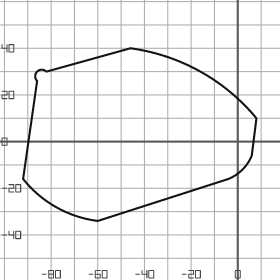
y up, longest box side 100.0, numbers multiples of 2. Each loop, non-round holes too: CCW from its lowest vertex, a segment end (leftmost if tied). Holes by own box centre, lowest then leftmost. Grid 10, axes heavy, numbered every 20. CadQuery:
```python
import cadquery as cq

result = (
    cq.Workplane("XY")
    .moveTo(-60.0, -34.0)
    .lineTo(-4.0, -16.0)
    .threePointArc((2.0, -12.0), (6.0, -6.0))
    .lineTo(8.0, 10.0)
    .threePointArc((-16.0, 30.0), (-46.0, 40.0))
    .lineTo(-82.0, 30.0)
    .threePointArc((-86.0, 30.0), (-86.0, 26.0))
    .lineTo(-92.0, -16.0)
    .threePointArc((-78.0, -28.0), (-60.0, -34.0))
    .close()
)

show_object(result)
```